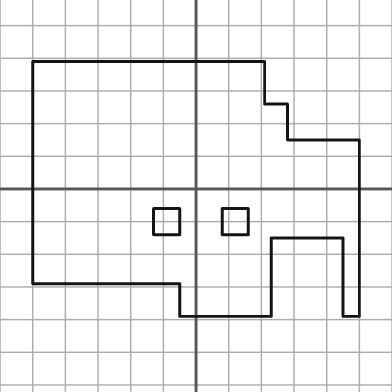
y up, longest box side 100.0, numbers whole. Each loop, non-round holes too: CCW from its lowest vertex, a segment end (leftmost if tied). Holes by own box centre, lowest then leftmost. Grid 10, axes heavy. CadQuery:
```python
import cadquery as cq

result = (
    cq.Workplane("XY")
    .moveTo(-5.0, -39.0)
    .lineTo(23.0, -39.0)
    .lineTo(23.0, -15.0)
    .lineTo(45.0, -15.0)
    .lineTo(45.0, -39.0)
    .lineTo(50.0, -39.0)
    .lineTo(50.0, 15.0)
    .lineTo(28.0, 15.0)
    .lineTo(28.0, 26.0)
    .lineTo(21.0, 26.0)
    .lineTo(21.0, 39.0)
    .lineTo(-50.0, 39.0)
    .lineTo(-50.0, -29.0)
    .lineTo(-5.0, -29.0)
    .close()
    .moveTo(-13.0, -14.0)
    .lineTo(-5.0, -14.0)
    .lineTo(-5.0, -6.0)
    .lineTo(-13.0, -6.0)
    .close()
    .moveTo(8.0, -14.0)
    .lineTo(16.0, -14.0)
    .lineTo(16.0, -6.0)
    .lineTo(8.0, -6.0)
    .close()
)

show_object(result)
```